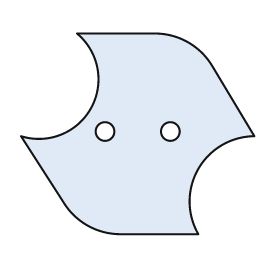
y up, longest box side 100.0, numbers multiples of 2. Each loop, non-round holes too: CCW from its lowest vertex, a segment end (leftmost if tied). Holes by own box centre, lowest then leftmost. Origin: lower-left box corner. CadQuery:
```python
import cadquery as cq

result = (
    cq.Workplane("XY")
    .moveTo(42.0, 0.0)
    .lineTo(76.0, 0.0)
    .threePointArc((76.0, 28.0), (100.0, 42.0))
    .lineTo(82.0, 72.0)
    .threePointArc((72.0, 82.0), (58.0, 86.0))
    .lineTo(24.0, 86.0)
    .threePointArc((30.0, 54.0), (0.0, 42.0))
    .lineTo(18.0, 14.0)
    .threePointArc((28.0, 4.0), (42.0, 0.0))
    .close()
    .moveTo(36.0, 44.0)
    .circle(4.0)
    .moveTo(64.0, 44.0)
    .circle(4.0)
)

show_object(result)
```